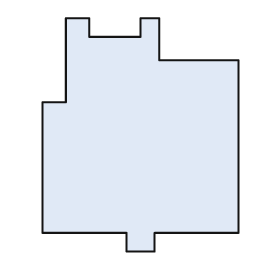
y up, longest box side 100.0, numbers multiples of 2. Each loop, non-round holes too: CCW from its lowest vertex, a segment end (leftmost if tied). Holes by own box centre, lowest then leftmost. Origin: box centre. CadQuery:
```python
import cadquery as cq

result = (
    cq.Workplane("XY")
    .moveTo(-6.0, -50.0)
    .lineTo(6.0, -50.0)
    .lineTo(6.0, -42.0)
    .lineTo(42.0, -42.0)
    .lineTo(42.0, 32.0)
    .lineTo(8.0, 32.0)
    .lineTo(8.0, 50.0)
    .lineTo(0.0, 50.0)
    .lineTo(0.0, 42.0)
    .lineTo(-22.0, 42.0)
    .lineTo(-22.0, 50.0)
    .lineTo(-32.0, 50.0)
    .lineTo(-32.0, 14.0)
    .lineTo(-42.0, 14.0)
    .lineTo(-42.0, -42.0)
    .lineTo(-6.0, -42.0)
    .close()
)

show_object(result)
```